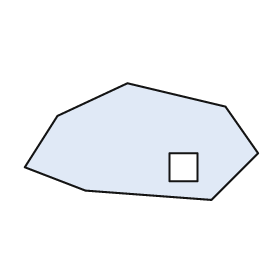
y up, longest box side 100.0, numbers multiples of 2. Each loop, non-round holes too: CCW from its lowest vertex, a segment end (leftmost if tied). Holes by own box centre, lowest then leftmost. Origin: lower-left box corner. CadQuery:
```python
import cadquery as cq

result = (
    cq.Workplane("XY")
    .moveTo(80.0, 0.0)
    .lineTo(100.0, 20.0)
    .lineTo(86.0, 40.0)
    .lineTo(44.0, 50.0)
    .lineTo(14.0, 36.0)
    .lineTo(0.0, 14.0)
    .lineTo(26.0, 4.0)
    .close()
    .moveTo(62.0, 8.0)
    .lineTo(74.0, 8.0)
    .lineTo(74.0, 20.0)
    .lineTo(62.0, 20.0)
    .close()
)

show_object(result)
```